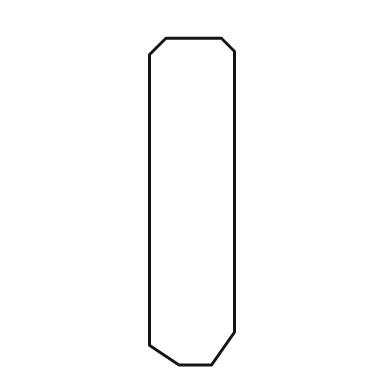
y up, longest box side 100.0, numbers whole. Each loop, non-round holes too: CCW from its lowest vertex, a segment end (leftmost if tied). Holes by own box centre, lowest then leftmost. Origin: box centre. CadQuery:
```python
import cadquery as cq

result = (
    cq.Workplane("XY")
    .moveTo(-4.0, -50.0)
    .lineTo(6.0, -50.0)
    .lineTo(13.0, -40.0)
    .lineTo(13.0, 46.0)
    .lineTo(9.0, 50.0)
    .lineTo(-8.0, 50.0)
    .lineTo(-13.0, 45.0)
    .lineTo(-13.0, -44.0)
    .close()
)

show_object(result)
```